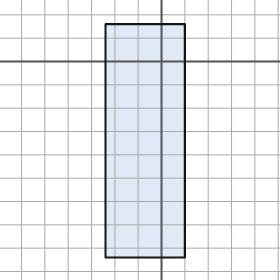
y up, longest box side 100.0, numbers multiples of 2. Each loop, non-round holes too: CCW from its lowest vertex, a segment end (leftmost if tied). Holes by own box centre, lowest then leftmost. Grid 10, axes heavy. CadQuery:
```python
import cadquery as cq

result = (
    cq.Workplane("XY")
    .moveTo(-24.0, -84.0)
    .lineTo(10.0, -84.0)
    .lineTo(10.0, 16.0)
    .lineTo(-24.0, 16.0)
    .close()
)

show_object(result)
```